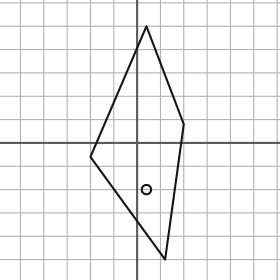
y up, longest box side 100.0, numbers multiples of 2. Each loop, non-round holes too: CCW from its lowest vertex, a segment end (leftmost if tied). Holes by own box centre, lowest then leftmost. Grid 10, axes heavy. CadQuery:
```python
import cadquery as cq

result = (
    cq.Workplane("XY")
    .moveTo(12.0, -50.0)
    .lineTo(20.0, 8.0)
    .lineTo(4.0, 50.0)
    .lineTo(-20.0, -6.0)
    .close()
    .moveTo(4.0, -20.0)
    .circle(2.0)
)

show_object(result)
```